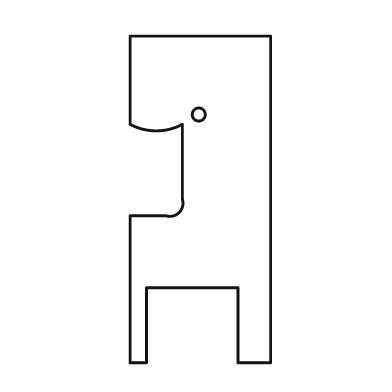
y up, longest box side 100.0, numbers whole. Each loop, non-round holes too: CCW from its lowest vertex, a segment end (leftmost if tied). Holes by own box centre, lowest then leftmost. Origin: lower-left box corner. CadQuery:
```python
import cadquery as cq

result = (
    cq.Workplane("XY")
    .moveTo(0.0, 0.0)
    .lineTo(5.0, 0.0)
    .lineTo(5.0, 23.0)
    .lineTo(33.0, 23.0)
    .lineTo(33.0, 0.0)
    .lineTo(43.0, 0.0)
    .lineTo(43.0, 100.0)
    .lineTo(0.0, 100.0)
    .lineTo(0.0, 73.0)
    .threePointArc((8.0, 71.0), (16.0, 73.0))
    .lineTo(16.0, 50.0)
    .threePointArc((15.0, 46.0), (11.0, 45.0))
    .lineTo(0.0, 45.0)
    .close()
    .moveTo(21.0, 76.0)
    .circle(2.0)
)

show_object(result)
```